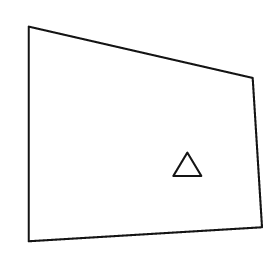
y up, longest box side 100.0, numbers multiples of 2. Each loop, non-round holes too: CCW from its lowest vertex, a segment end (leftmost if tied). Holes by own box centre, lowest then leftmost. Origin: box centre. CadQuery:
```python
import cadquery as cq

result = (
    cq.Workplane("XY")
    .moveTo(-50.0, -46.0)
    .lineTo(50.0, -40.0)
    .lineTo(46.0, 24.0)
    .lineTo(-50.0, 46.0)
    .close()
    .moveTo(12.0, -18.0)
    .lineTo(24.0, -18.0)
    .lineTo(18.0, -8.0)
    .close()
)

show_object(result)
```